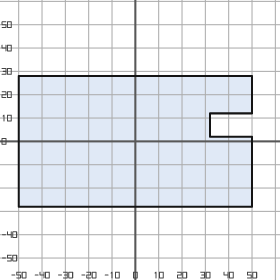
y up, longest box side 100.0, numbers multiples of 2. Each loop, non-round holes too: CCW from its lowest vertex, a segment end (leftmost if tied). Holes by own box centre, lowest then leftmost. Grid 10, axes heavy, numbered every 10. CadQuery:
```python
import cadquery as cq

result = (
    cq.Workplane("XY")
    .moveTo(-50.0, -28.0)
    .lineTo(50.0, -28.0)
    .lineTo(50.0, 2.0)
    .lineTo(32.0, 2.0)
    .lineTo(32.0, 12.0)
    .lineTo(50.0, 12.0)
    .lineTo(50.0, 28.0)
    .lineTo(-50.0, 28.0)
    .close()
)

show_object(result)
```